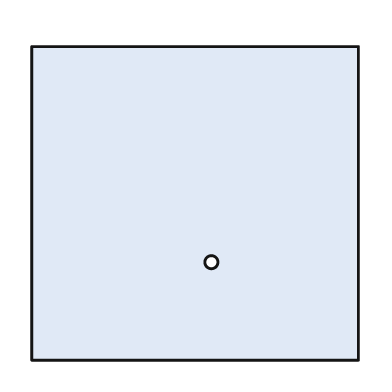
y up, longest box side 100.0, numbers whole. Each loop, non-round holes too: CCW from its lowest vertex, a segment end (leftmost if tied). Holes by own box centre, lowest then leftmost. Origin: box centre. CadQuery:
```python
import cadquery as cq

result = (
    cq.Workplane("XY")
    .moveTo(-50.0, -48.0)
    .lineTo(50.0, -48.0)
    .lineTo(50.0, 48.0)
    .lineTo(-50.0, 48.0)
    .close()
    .moveTo(5.0, -18.0)
    .circle(2.0)
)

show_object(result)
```